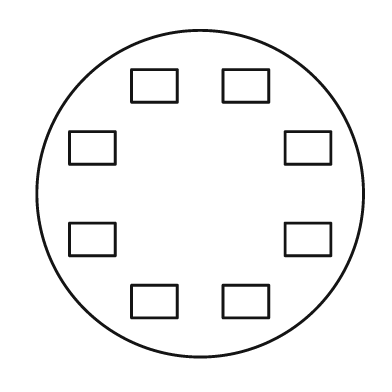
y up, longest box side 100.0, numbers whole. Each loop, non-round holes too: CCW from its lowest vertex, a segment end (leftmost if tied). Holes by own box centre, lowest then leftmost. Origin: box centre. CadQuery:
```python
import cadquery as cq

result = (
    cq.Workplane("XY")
    .moveTo(0.0, 0.0)
    .circle(50.0)
    .moveTo(-21.0, -38.0)
    .lineTo(-7.0, -38.0)
    .lineTo(-7.0, -28.0)
    .lineTo(-21.0, -28.0)
    .close()
    .moveTo(7.0, -38.0)
    .lineTo(21.0, -38.0)
    .lineTo(21.0, -28.0)
    .lineTo(7.0, -28.0)
    .close()
    .moveTo(-40.0, -19.0)
    .lineTo(-26.0, -19.0)
    .lineTo(-26.0, -9.0)
    .lineTo(-40.0, -9.0)
    .close()
    .moveTo(26.0, -19.0)
    .lineTo(40.0, -19.0)
    .lineTo(40.0, -9.0)
    .lineTo(26.0, -9.0)
    .close()
    .moveTo(-40.0, 9.0)
    .lineTo(-26.0, 9.0)
    .lineTo(-26.0, 19.0)
    .lineTo(-40.0, 19.0)
    .close()
    .moveTo(26.0, 9.0)
    .lineTo(40.0, 9.0)
    .lineTo(40.0, 19.0)
    .lineTo(26.0, 19.0)
    .close()
    .moveTo(-21.0, 28.0)
    .lineTo(-7.0, 28.0)
    .lineTo(-7.0, 38.0)
    .lineTo(-21.0, 38.0)
    .close()
    .moveTo(7.0, 28.0)
    .lineTo(21.0, 28.0)
    .lineTo(21.0, 38.0)
    .lineTo(7.0, 38.0)
    .close()
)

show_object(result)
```